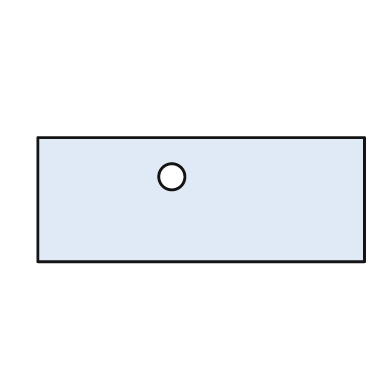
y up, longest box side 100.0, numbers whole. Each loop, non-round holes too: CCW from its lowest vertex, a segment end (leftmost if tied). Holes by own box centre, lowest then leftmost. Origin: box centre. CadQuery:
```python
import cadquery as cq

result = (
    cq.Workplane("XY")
    .moveTo(-50.0, -19.0)
    .lineTo(50.0, -19.0)
    .lineTo(50.0, 19.0)
    .lineTo(-50.0, 19.0)
    .close()
    .moveTo(-9.0, 7.0)
    .circle(4.0)
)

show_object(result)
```